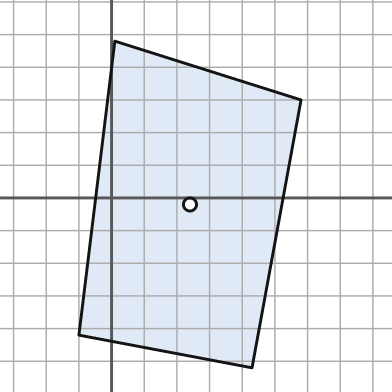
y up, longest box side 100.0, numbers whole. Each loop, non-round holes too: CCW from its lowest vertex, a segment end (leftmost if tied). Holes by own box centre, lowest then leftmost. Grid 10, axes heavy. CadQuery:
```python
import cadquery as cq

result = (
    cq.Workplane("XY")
    .moveTo(43.0, -52.0)
    .lineTo(58.0, 30.0)
    .lineTo(1.0, 48.0)
    .lineTo(-10.0, -42.0)
    .close()
    .moveTo(24.0, -2.0)
    .circle(2.0)
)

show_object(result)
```